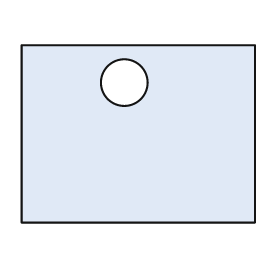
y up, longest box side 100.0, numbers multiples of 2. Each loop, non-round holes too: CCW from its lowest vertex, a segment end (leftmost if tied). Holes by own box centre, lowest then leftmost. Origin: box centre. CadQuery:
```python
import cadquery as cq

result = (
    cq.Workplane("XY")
    .moveTo(-50.0, -38.0)
    .lineTo(50.0, -38.0)
    .lineTo(50.0, 38.0)
    .lineTo(-50.0, 38.0)
    .close()
    .moveTo(-6.0, 22.0)
    .circle(10.0)
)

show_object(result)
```